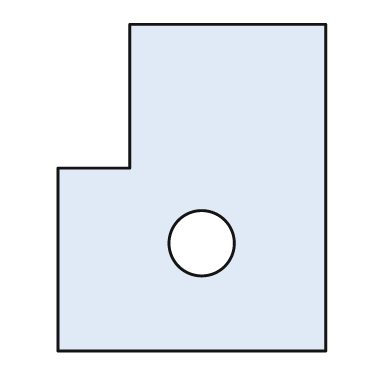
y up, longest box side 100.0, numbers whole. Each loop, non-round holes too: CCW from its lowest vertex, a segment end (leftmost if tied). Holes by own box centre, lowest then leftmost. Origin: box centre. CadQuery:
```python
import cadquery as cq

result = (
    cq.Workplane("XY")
    .moveTo(-41.0, -50.0)
    .lineTo(41.0, -50.0)
    .lineTo(41.0, 50.0)
    .lineTo(-19.0, 50.0)
    .lineTo(-19.0, 6.0)
    .lineTo(-41.0, 6.0)
    .close()
    .moveTo(3.0, -17.0)
    .circle(10.0)
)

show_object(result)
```